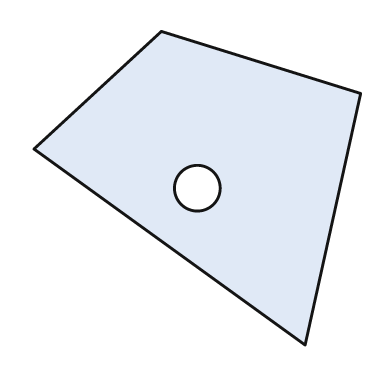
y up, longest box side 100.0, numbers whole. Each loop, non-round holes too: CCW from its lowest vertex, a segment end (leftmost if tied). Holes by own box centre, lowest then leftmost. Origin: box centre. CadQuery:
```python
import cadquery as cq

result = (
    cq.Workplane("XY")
    .moveTo(33.0, -48.0)
    .lineTo(50.0, 29.0)
    .lineTo(-11.0, 48.0)
    .lineTo(-50.0, 12.0)
    .close()
    .moveTo(0.0, 0.0)
    .circle(7.0)
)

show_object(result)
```